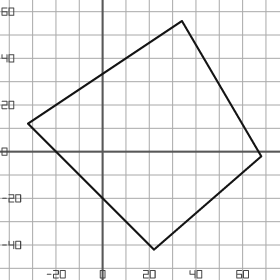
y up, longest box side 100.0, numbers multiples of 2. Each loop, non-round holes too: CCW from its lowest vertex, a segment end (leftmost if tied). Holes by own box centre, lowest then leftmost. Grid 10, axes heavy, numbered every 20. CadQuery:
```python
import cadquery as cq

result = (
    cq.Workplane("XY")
    .moveTo(22.0, -42.0)
    .lineTo(68.0, -2.0)
    .lineTo(34.0, 56.0)
    .lineTo(-32.0, 12.0)
    .close()
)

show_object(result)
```